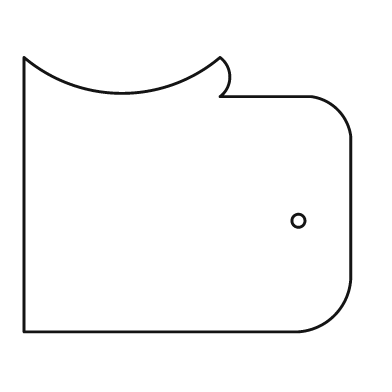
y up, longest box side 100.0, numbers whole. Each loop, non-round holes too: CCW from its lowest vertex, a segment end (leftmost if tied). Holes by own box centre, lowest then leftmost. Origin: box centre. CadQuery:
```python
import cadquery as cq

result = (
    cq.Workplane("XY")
    .moveTo(-50.0, -42.0)
    .lineTo(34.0, -42.0)
    .threePointArc((45.0, -37.0), (50.0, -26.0))
    .lineTo(50.0, 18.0)
    .threePointArc((46.0, 26.0), (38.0, 30.0))
    .lineTo(10.0, 30.0)
    .threePointArc((13.0, 36.0), (10.0, 42.0))
    .threePointArc((-20.0, 31.0), (-50.0, 42.0))
    .close()
    .moveTo(34.0, -8.0)
    .circle(2.0)
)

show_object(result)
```